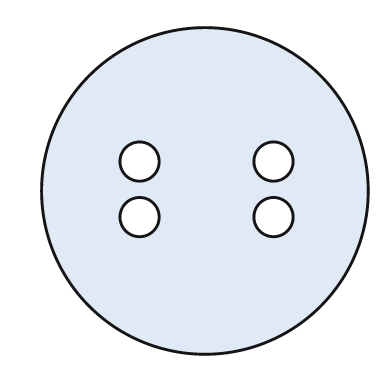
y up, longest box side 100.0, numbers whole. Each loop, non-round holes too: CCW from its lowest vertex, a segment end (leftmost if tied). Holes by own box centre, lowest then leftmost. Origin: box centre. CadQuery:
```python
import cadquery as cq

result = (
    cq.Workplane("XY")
    .moveTo(0.0, 0.0)
    .circle(50.0)
    .moveTo(-20.0, -8.0)
    .circle(6.0)
    .moveTo(21.0, -8.0)
    .circle(6.0)
    .moveTo(-20.0, 9.0)
    .circle(6.0)
    .moveTo(21.0, 9.0)
    .circle(6.0)
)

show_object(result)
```